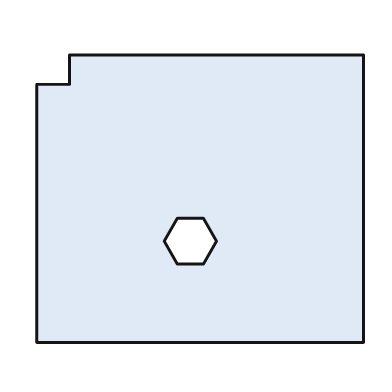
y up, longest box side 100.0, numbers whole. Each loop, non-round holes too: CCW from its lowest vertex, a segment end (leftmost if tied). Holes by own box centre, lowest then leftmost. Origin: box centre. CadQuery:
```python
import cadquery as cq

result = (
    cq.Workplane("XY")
    .moveTo(-50.0, -44.0)
    .lineTo(50.0, -44.0)
    .lineTo(50.0, 44.0)
    .lineTo(-40.0, 44.0)
    .lineTo(-40.0, 35.0)
    .lineTo(-50.0, 35.0)
    .close()
    .moveTo(-7.0, -20.0)
    .lineTo(1.0, -20.0)
    .lineTo(5.0, -13.0)
    .lineTo(1.0, -6.0)
    .lineTo(-7.0, -6.0)
    .lineTo(-11.0, -13.0)
    .close()
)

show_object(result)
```